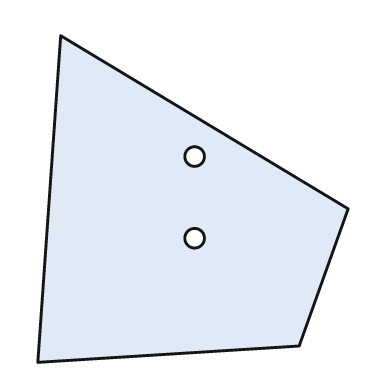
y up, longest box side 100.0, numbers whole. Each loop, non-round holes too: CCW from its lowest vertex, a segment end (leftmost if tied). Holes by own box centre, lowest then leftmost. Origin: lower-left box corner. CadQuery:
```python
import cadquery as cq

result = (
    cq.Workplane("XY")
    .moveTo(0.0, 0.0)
    .lineTo(80.0, 5.0)
    .lineTo(95.0, 47.0)
    .lineTo(7.0, 100.0)
    .close()
    .moveTo(48.0, 38.0)
    .circle(3.0)
    .moveTo(48.0, 63.0)
    .circle(3.0)
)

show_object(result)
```